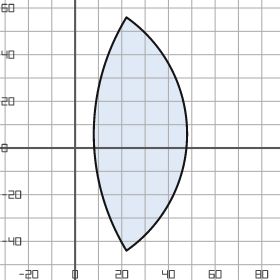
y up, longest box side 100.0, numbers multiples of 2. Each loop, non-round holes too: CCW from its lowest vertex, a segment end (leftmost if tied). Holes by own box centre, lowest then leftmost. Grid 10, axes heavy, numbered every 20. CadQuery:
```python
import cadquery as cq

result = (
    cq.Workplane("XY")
    .moveTo(22.0, -44.0)
    .threePointArc((48.0, 6.0), (22.0, 56.0))
    .threePointArc((8.0, 6.0), (22.0, -44.0))
    .close()
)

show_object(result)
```